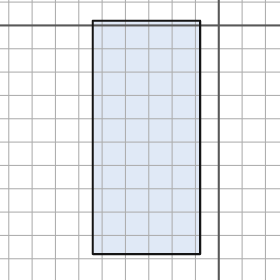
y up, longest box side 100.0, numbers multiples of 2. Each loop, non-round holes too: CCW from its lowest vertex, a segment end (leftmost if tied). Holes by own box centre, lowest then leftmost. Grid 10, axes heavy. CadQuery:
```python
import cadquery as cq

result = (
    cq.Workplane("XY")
    .moveTo(-54.0, -98.0)
    .lineTo(-8.0, -98.0)
    .lineTo(-8.0, 2.0)
    .lineTo(-54.0, 2.0)
    .close()
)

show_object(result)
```